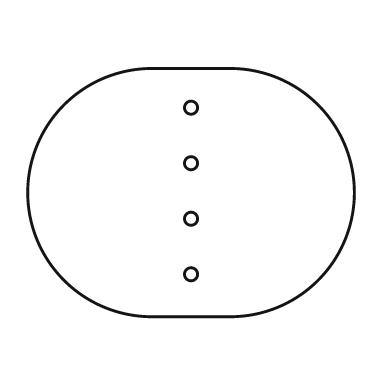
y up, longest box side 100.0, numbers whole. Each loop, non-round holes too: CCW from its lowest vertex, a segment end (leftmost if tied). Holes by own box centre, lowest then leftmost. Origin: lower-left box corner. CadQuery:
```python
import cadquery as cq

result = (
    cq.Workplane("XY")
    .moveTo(38.0, 0.0)
    .lineTo(62.0, 0.0)
    .threePointArc((100.0, 38.0), (62.0, 76.0))
    .lineTo(38.0, 76.0)
    .threePointArc((0.0, 38.0), (38.0, 0.0))
    .close()
    .moveTo(50.0, 13.0)
    .circle(2.0)
    .moveTo(50.0, 30.0)
    .circle(2.0)
    .moveTo(50.0, 47.0)
    .circle(2.0)
    .moveTo(50.0, 64.0)
    .circle(2.0)
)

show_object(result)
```